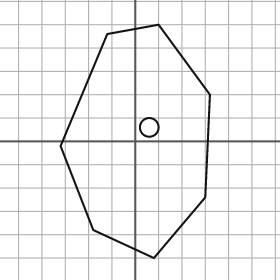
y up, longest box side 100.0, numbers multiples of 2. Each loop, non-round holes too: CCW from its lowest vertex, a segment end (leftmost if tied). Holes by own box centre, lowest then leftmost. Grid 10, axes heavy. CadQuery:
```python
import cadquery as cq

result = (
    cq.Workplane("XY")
    .moveTo(8.0, -50.0)
    .lineTo(30.0, -24.0)
    .lineTo(32.0, 20.0)
    .lineTo(10.0, 50.0)
    .lineTo(-12.0, 46.0)
    .lineTo(-32.0, -2.0)
    .lineTo(-18.0, -38.0)
    .close()
    .moveTo(6.0, 6.0)
    .circle(4.0)
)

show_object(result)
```